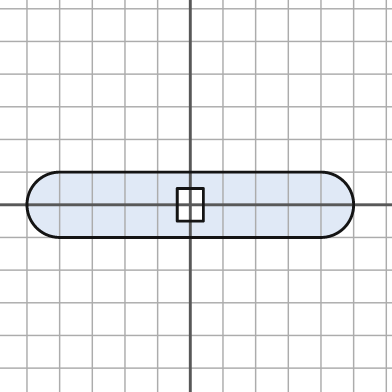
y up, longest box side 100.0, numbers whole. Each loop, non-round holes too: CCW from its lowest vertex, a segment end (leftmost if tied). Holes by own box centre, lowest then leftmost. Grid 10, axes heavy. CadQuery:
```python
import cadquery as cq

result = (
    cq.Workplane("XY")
    .moveTo(-40.0, -10.0)
    .lineTo(40.0, -10.0)
    .threePointArc((50.0, 0.0), (40.0, 10.0))
    .lineTo(-40.0, 10.0)
    .threePointArc((-50.0, 0.0), (-40.0, -10.0))
    .close()
    .moveTo(-4.0, -5.0)
    .lineTo(4.0, -5.0)
    .lineTo(4.0, 5.0)
    .lineTo(-4.0, 5.0)
    .close()
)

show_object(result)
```